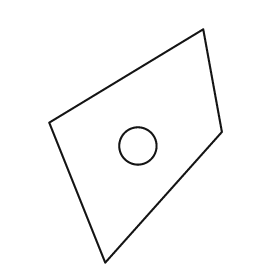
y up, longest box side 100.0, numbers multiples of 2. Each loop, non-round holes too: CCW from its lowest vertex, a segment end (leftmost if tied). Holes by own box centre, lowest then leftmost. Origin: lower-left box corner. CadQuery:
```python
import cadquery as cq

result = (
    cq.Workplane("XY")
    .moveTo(24.0, 0.0)
    .lineTo(74.0, 56.0)
    .lineTo(66.0, 100.0)
    .lineTo(0.0, 60.0)
    .close()
    .moveTo(38.0, 50.0)
    .circle(8.0)
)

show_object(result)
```